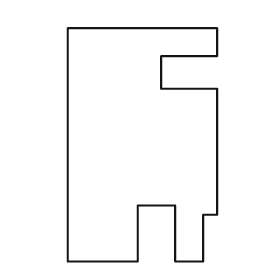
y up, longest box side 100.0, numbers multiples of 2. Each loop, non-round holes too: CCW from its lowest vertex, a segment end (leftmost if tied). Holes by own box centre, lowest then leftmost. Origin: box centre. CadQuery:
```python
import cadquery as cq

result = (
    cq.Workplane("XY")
    .moveTo(-32.0, -50.0)
    .lineTo(-2.0, -50.0)
    .lineTo(-2.0, -26.0)
    .lineTo(14.0, -26.0)
    .lineTo(14.0, -50.0)
    .lineTo(26.0, -50.0)
    .lineTo(26.0, -30.0)
    .lineTo(32.0, -30.0)
    .lineTo(32.0, 24.0)
    .lineTo(8.0, 24.0)
    .lineTo(8.0, 38.0)
    .lineTo(32.0, 38.0)
    .lineTo(32.0, 50.0)
    .lineTo(-32.0, 50.0)
    .close()
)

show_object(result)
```